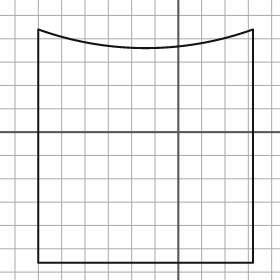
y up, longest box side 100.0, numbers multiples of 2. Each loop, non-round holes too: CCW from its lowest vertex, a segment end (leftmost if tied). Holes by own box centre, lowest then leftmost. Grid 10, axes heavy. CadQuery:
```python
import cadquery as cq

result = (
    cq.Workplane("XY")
    .moveTo(-60.0, -56.0)
    .lineTo(32.0, -56.0)
    .lineTo(32.0, 44.0)
    .threePointArc((-14.0, 36.0), (-60.0, 44.0))
    .close()
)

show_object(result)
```